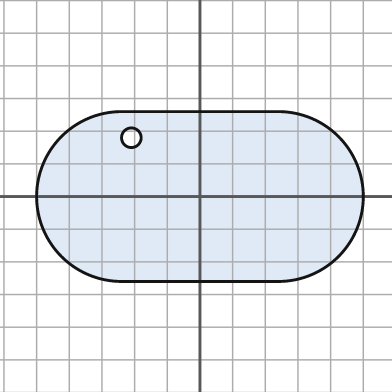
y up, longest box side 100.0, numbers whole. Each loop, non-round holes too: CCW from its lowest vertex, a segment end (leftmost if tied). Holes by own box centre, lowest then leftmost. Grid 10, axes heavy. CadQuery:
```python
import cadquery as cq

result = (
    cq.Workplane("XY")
    .moveTo(-24.0, -26.0)
    .lineTo(24.0, -26.0)
    .threePointArc((50.0, 0.0), (24.0, 26.0))
    .lineTo(-24.0, 26.0)
    .threePointArc((-50.0, 0.0), (-24.0, -26.0))
    .close()
    .moveTo(-21.0, 18.0)
    .circle(3.0)
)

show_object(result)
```